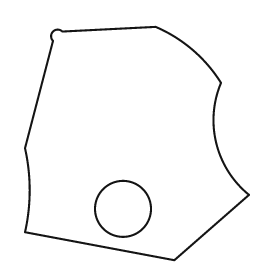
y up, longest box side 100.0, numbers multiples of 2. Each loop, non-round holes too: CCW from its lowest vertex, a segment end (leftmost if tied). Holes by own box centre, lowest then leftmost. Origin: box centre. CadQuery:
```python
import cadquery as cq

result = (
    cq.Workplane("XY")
    .moveTo(16.0, -50.0)
    .lineTo(48.0, -22.0)
    .threePointArc((34.0, 0.0), (36.0, 26.0))
    .threePointArc((24.0, 40.0), (8.0, 50.0))
    .lineTo(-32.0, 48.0)
    .threePointArc((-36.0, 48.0), (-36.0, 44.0))
    .lineTo(-48.0, -2.0)
    .threePointArc((-46.0, -20.0), (-48.0, -38.0))
    .close()
    .moveTo(-6.0, -28.0)
    .circle(12.0)
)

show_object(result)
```